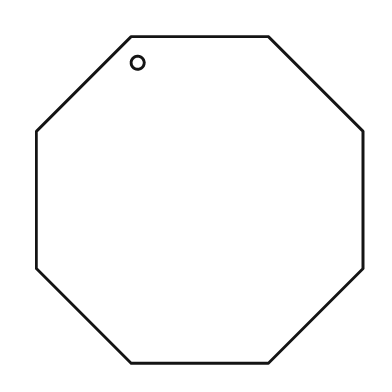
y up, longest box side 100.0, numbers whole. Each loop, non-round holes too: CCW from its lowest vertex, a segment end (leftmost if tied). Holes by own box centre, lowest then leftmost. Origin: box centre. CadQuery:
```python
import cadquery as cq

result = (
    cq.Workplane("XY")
    .moveTo(-21.0, -50.0)
    .lineTo(21.0, -50.0)
    .lineTo(50.0, -21.0)
    .lineTo(50.0, 21.0)
    .lineTo(21.0, 50.0)
    .lineTo(-21.0, 50.0)
    .lineTo(-50.0, 21.0)
    .lineTo(-50.0, -21.0)
    .close()
    .moveTo(-19.0, 42.0)
    .circle(2.0)
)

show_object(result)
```